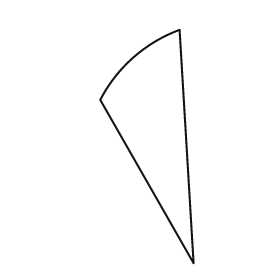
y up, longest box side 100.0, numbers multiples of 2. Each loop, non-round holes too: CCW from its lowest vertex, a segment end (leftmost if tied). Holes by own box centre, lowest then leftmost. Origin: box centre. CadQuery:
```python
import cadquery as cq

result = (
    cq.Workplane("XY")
    .moveTo(20.0, -50.0)
    .lineTo(14.0, 50.0)
    .threePointArc((-6.0, 38.0), (-20.0, 20.0))
    .close()
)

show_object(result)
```